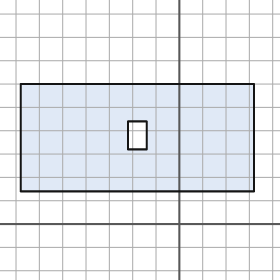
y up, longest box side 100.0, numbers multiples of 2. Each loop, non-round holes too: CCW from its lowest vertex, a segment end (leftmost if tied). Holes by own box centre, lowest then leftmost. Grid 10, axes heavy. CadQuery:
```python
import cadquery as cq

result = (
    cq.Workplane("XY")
    .moveTo(-68.0, 14.0)
    .lineTo(32.0, 14.0)
    .lineTo(32.0, 60.0)
    .lineTo(-68.0, 60.0)
    .close()
    .moveTo(-22.0, 32.0)
    .lineTo(-14.0, 32.0)
    .lineTo(-14.0, 44.0)
    .lineTo(-22.0, 44.0)
    .close()
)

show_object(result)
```